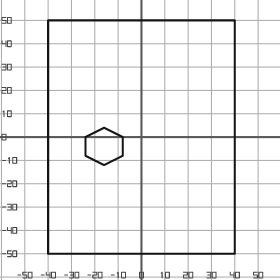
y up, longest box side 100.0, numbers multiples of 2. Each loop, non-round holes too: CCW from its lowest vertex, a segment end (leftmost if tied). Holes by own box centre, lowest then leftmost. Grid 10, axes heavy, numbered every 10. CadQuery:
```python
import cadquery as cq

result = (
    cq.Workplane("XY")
    .moveTo(-40.0, -50.0)
    .lineTo(40.0, -50.0)
    .lineTo(40.0, 50.0)
    .lineTo(-40.0, 50.0)
    .close()
    .moveTo(-16.0, -12.0)
    .lineTo(-8.0, -8.0)
    .lineTo(-8.0, 0.0)
    .lineTo(-16.0, 4.0)
    .lineTo(-24.0, 0.0)
    .lineTo(-24.0, -8.0)
    .close()
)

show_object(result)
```